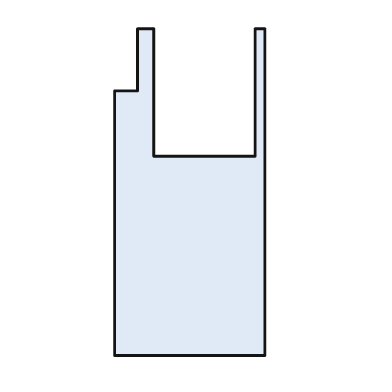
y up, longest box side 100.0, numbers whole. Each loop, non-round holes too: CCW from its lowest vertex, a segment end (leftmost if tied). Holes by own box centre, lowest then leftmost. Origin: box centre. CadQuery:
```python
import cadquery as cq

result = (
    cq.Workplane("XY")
    .moveTo(-23.0, -50.0)
    .lineTo(23.0, -50.0)
    .lineTo(23.0, 50.0)
    .lineTo(20.0, 50.0)
    .lineTo(20.0, 11.0)
    .lineTo(-11.0, 11.0)
    .lineTo(-11.0, 50.0)
    .lineTo(-16.0, 50.0)
    .lineTo(-16.0, 31.0)
    .lineTo(-23.0, 31.0)
    .close()
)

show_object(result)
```